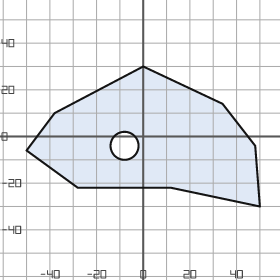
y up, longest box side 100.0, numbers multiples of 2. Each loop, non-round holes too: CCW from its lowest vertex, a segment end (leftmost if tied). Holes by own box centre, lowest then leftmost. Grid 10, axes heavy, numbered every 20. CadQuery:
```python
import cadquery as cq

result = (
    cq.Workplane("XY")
    .moveTo(50.0, -30.0)
    .lineTo(48.0, -4.0)
    .lineTo(34.0, 14.0)
    .lineTo(0.0, 30.0)
    .lineTo(-38.0, 10.0)
    .lineTo(-50.0, -6.0)
    .lineTo(-28.0, -22.0)
    .lineTo(12.0, -22.0)
    .close()
    .moveTo(-8.0, -4.0)
    .circle(6.0)
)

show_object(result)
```